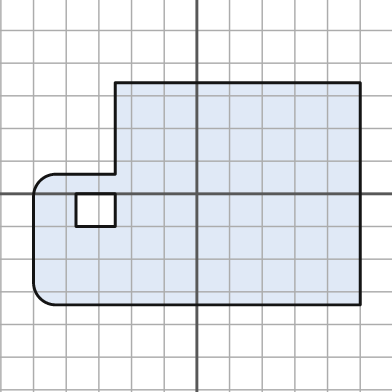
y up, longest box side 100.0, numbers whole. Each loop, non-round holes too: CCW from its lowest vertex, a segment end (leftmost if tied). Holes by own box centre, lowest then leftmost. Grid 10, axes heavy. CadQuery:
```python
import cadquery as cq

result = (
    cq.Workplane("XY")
    .moveTo(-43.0, -34.0)
    .lineTo(50.0, -34.0)
    .lineTo(50.0, 34.0)
    .lineTo(-25.0, 34.0)
    .lineTo(-25.0, 6.0)
    .lineTo(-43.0, 6.0)
    .threePointArc((-48.0, 4.0), (-50.0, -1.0))
    .lineTo(-50.0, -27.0)
    .threePointArc((-48.0, -32.0), (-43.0, -34.0))
    .close()
    .moveTo(-37.0, -10.0)
    .lineTo(-25.0, -10.0)
    .lineTo(-25.0, 0.0)
    .lineTo(-37.0, 0.0)
    .close()
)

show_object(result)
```